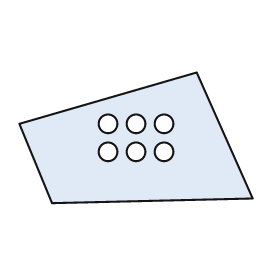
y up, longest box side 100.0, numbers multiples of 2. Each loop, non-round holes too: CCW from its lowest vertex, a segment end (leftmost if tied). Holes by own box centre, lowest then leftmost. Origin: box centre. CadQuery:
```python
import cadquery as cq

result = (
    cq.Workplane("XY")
    .moveTo(-36.0, -28.0)
    .lineTo(50.0, -26.0)
    .lineTo(26.0, 28.0)
    .lineTo(-50.0, 6.0)
    .close()
    .moveTo(-12.0, -6.0)
    .circle(4.0)
    .moveTo(0.0, -6.0)
    .circle(4.0)
    .moveTo(12.0, -6.0)
    .circle(4.0)
    .moveTo(-12.0, 6.0)
    .circle(4.0)
    .moveTo(0.0, 6.0)
    .circle(4.0)
    .moveTo(12.0, 6.0)
    .circle(4.0)
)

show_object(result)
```